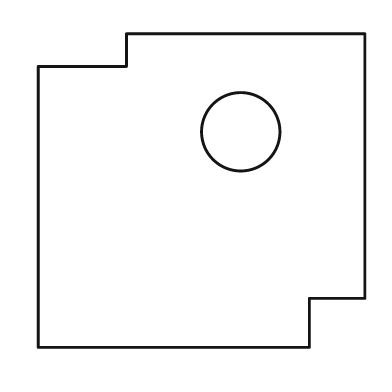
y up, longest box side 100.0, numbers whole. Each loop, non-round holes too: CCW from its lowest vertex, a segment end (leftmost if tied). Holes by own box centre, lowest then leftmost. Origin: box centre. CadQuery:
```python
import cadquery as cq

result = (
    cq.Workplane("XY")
    .moveTo(-50.0, -48.0)
    .lineTo(33.0, -48.0)
    .lineTo(33.0, -33.0)
    .lineTo(50.0, -33.0)
    .lineTo(50.0, 48.0)
    .lineTo(-23.0, 48.0)
    .lineTo(-23.0, 38.0)
    .lineTo(-50.0, 38.0)
    .close()
    .moveTo(12.0, 18.0)
    .circle(12.0)
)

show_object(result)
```